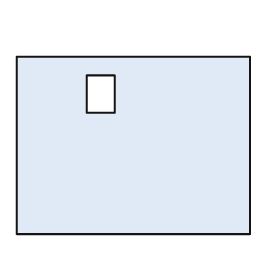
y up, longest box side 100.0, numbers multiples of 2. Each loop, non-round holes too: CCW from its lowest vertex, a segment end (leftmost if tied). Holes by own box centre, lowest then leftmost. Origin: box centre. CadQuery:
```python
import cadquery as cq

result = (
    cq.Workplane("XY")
    .moveTo(-50.0, -38.0)
    .lineTo(50.0, -38.0)
    .lineTo(50.0, 38.0)
    .lineTo(-50.0, 38.0)
    .close()
    .moveTo(-20.0, 14.0)
    .lineTo(-8.0, 14.0)
    .lineTo(-8.0, 30.0)
    .lineTo(-20.0, 30.0)
    .close()
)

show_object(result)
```